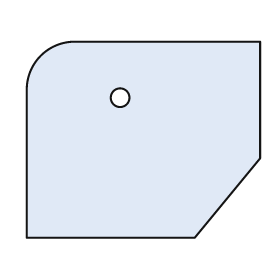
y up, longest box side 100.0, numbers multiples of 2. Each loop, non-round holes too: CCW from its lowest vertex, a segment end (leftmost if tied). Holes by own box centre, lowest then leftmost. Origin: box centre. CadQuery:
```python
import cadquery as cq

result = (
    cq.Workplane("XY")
    .moveTo(-50.0, -42.0)
    .lineTo(22.0, -42.0)
    .lineTo(50.0, -8.0)
    .lineTo(50.0, 42.0)
    .lineTo(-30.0, 42.0)
    .threePointArc((-44.0, 36.0), (-50.0, 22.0))
    .close()
    .moveTo(-10.0, 18.0)
    .circle(4.0)
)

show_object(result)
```